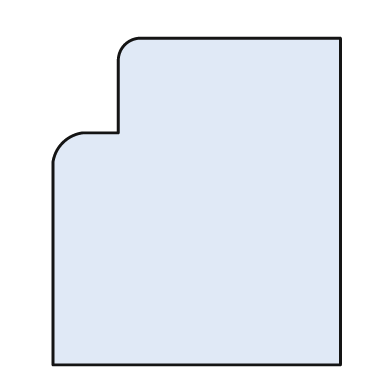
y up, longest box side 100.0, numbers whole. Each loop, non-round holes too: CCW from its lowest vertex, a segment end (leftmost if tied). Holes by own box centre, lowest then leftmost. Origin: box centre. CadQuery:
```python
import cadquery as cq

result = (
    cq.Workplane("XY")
    .moveTo(-44.0, -50.0)
    .lineTo(44.0, -50.0)
    .lineTo(44.0, 50.0)
    .lineTo(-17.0, 50.0)
    .threePointArc((-22.0, 48.0), (-24.0, 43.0))
    .lineTo(-24.0, 21.0)
    .lineTo(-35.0, 21.0)
    .threePointArc((-41.0, 18.0), (-44.0, 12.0))
    .close()
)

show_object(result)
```